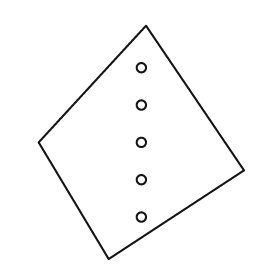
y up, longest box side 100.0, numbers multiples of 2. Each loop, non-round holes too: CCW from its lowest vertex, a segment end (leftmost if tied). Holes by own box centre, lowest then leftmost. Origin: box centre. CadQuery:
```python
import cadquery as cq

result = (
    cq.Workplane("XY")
    .moveTo(-14.0, -50.0)
    .lineTo(44.0, -12.0)
    .lineTo(2.0, 50.0)
    .lineTo(-44.0, 0.0)
    .close()
    .moveTo(0.0, -32.0)
    .circle(2.0)
    .moveTo(0.0, -16.0)
    .circle(2.0)
    .moveTo(0.0, 0.0)
    .circle(2.0)
    .moveTo(0.0, 16.0)
    .circle(2.0)
    .moveTo(0.0, 32.0)
    .circle(2.0)
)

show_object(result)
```